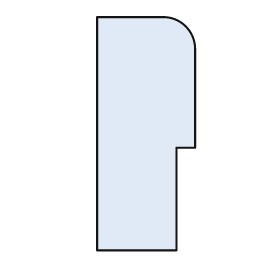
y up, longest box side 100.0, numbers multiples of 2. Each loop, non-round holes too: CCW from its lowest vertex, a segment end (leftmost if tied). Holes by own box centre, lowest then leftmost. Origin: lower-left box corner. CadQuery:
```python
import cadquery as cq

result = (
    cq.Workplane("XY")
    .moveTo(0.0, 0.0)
    .lineTo(34.0, 0.0)
    .lineTo(34.0, 44.0)
    .lineTo(42.0, 44.0)
    .lineTo(42.0, 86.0)
    .threePointArc((38.0, 96.0), (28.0, 100.0))
    .lineTo(0.0, 100.0)
    .close()
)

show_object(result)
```